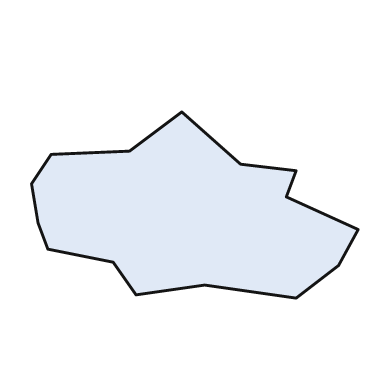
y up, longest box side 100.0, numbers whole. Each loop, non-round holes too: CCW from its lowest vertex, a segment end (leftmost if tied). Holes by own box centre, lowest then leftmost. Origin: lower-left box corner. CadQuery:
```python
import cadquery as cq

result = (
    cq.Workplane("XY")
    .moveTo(81.0, 0.0)
    .lineTo(94.0, 10.0)
    .lineTo(100.0, 21.0)
    .lineTo(78.0, 31.0)
    .lineTo(81.0, 39.0)
    .lineTo(64.0, 41.0)
    .lineTo(46.0, 57.0)
    .lineTo(30.0, 45.0)
    .lineTo(6.0, 44.0)
    .lineTo(0.0, 35.0)
    .lineTo(2.0, 23.0)
    .lineTo(5.0, 15.0)
    .lineTo(25.0, 11.0)
    .lineTo(32.0, 1.0)
    .lineTo(53.0, 4.0)
    .close()
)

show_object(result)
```